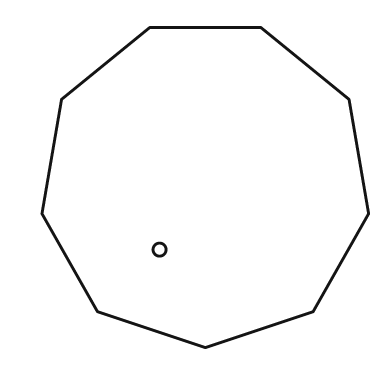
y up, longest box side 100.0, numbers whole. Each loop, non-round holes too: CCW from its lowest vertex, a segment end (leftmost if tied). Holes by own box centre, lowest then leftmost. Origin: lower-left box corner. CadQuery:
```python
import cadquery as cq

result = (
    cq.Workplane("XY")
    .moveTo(50.0, 0.0)
    .lineTo(83.0, 11.0)
    .lineTo(100.0, 41.0)
    .lineTo(94.0, 76.0)
    .lineTo(67.0, 98.0)
    .lineTo(33.0, 98.0)
    .lineTo(6.0, 76.0)
    .lineTo(0.0, 41.0)
    .lineTo(17.0, 11.0)
    .close()
    .moveTo(36.0, 30.0)
    .circle(2.0)
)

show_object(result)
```